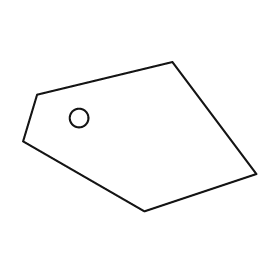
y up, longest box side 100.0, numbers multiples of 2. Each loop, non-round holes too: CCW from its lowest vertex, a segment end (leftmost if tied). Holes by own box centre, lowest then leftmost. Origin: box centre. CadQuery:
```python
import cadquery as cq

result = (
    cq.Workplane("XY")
    .moveTo(2.0, -32.0)
    .lineTo(50.0, -16.0)
    .lineTo(14.0, 32.0)
    .lineTo(-44.0, 18.0)
    .lineTo(-50.0, -2.0)
    .close()
    .moveTo(-26.0, 8.0)
    .circle(4.0)
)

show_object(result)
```